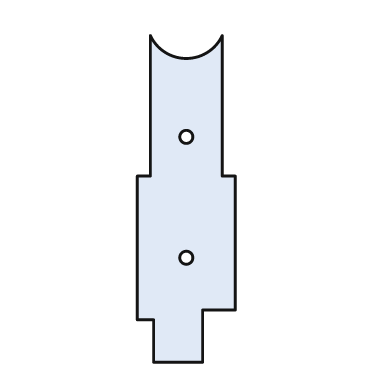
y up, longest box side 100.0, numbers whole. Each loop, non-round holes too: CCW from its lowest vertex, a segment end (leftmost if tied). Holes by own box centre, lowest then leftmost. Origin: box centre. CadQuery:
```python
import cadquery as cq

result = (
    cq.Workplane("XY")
    .moveTo(-10.0, -50.0)
    .lineTo(5.0, -50.0)
    .lineTo(5.0, -34.0)
    .lineTo(15.0, -34.0)
    .lineTo(15.0, 7.0)
    .lineTo(11.0, 7.0)
    .lineTo(11.0, 50.0)
    .threePointArc((0.0, 43.0), (-11.0, 50.0))
    .lineTo(-11.0, 7.0)
    .lineTo(-15.0, 7.0)
    .lineTo(-15.0, -37.0)
    .lineTo(-10.0, -37.0)
    .close()
    .moveTo(0.0, -18.0)
    .circle(2.0)
    .moveTo(0.0, 19.0)
    .circle(2.0)
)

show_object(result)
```